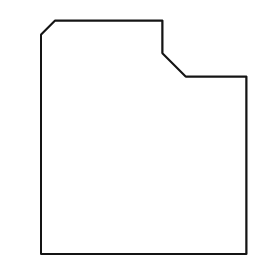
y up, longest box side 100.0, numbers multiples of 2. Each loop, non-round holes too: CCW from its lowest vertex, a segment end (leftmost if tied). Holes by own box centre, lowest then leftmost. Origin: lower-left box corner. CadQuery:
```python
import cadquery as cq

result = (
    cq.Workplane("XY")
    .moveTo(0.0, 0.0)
    .lineTo(88.0, 0.0)
    .lineTo(88.0, 76.0)
    .lineTo(62.0, 76.0)
    .lineTo(52.0, 86.0)
    .lineTo(52.0, 100.0)
    .lineTo(6.0, 100.0)
    .lineTo(0.0, 94.0)
    .close()
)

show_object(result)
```